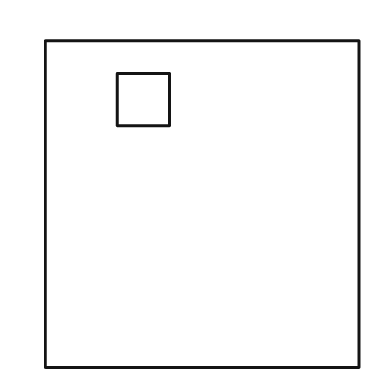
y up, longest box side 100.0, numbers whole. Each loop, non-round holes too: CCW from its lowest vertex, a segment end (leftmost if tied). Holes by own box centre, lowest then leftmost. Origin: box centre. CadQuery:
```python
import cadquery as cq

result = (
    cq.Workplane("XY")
    .moveTo(-48.0, -50.0)
    .lineTo(48.0, -50.0)
    .lineTo(48.0, 50.0)
    .lineTo(-48.0, 50.0)
    .close()
    .moveTo(-26.0, 24.0)
    .lineTo(-10.0, 24.0)
    .lineTo(-10.0, 40.0)
    .lineTo(-26.0, 40.0)
    .close()
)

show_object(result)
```